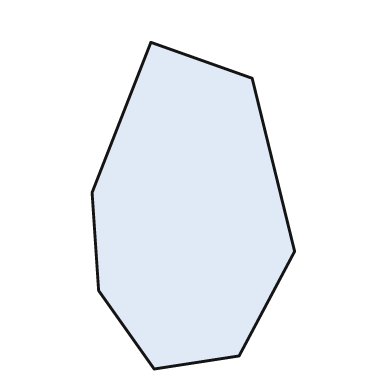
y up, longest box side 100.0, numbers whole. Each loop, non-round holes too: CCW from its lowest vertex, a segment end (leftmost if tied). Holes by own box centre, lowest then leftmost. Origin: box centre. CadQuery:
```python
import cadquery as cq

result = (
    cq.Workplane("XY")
    .moveTo(-12.0, -50.0)
    .lineTo(14.0, -46.0)
    .lineTo(31.0, -14.0)
    .lineTo(18.0, 39.0)
    .lineTo(-13.0, 50.0)
    .lineTo(-31.0, 4.0)
    .lineTo(-29.0, -26.0)
    .close()
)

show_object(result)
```